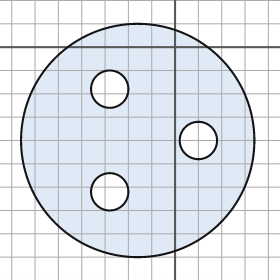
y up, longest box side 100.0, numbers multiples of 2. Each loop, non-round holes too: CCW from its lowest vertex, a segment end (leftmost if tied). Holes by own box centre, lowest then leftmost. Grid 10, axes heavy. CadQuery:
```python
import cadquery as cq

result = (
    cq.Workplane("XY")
    .moveTo(-16.0, -40.0)
    .circle(50.0)
    .moveTo(-28.0, -62.0)
    .circle(8.0)
    .moveTo(10.0, -40.0)
    .circle(8.0)
    .moveTo(-28.0, -18.0)
    .circle(8.0)
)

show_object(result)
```